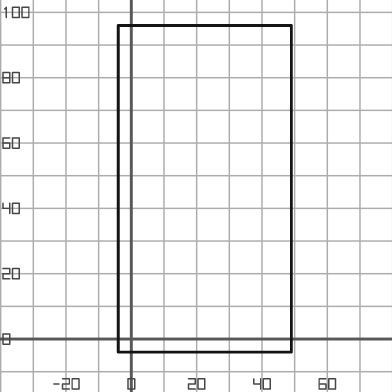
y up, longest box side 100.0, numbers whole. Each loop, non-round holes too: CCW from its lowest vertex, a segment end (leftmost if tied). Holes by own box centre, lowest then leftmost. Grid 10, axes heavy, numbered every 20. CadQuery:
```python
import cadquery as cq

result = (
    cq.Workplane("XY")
    .moveTo(-4.0, -4.0)
    .lineTo(49.0, -4.0)
    .lineTo(49.0, 96.0)
    .lineTo(-4.0, 96.0)
    .close()
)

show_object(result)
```